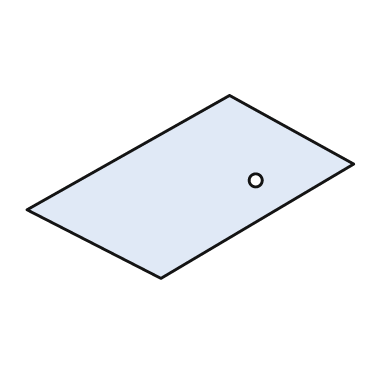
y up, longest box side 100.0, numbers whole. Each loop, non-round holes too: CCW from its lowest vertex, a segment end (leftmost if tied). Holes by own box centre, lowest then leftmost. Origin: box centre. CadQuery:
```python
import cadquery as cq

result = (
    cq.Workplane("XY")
    .moveTo(-9.0, -28.0)
    .lineTo(50.0, 7.0)
    .lineTo(12.0, 28.0)
    .lineTo(-50.0, -7.0)
    .close()
    .moveTo(20.0, 2.0)
    .circle(2.0)
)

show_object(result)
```